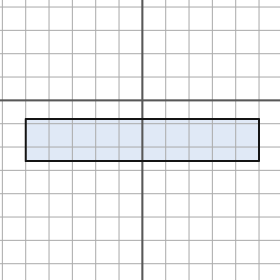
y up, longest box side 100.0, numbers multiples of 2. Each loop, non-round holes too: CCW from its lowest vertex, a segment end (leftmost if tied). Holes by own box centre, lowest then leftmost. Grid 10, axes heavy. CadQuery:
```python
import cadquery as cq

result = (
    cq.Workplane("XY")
    .moveTo(-50.0, -26.0)
    .lineTo(50.0, -26.0)
    .lineTo(50.0, -8.0)
    .lineTo(-50.0, -8.0)
    .close()
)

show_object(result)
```